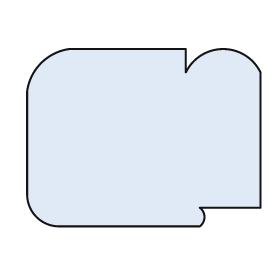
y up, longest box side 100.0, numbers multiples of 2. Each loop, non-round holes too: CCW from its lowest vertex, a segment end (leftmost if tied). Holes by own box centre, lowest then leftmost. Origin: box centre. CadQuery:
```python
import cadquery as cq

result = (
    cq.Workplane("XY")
    .moveTo(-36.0, -38.0)
    .lineTo(24.0, -38.0)
    .threePointArc((26.0, -34.0), (24.0, -30.0))
    .lineTo(50.0, -30.0)
    .lineTo(50.0, 28.0)
    .threePointArc((34.0, 38.0), (18.0, 28.0))
    .lineTo(18.0, 38.0)
    .lineTo(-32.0, 38.0)
    .threePointArc((-44.0, 32.0), (-50.0, 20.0))
    .lineTo(-50.0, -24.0)
    .threePointArc((-46.0, -34.0), (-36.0, -38.0))
    .close()
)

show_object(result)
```